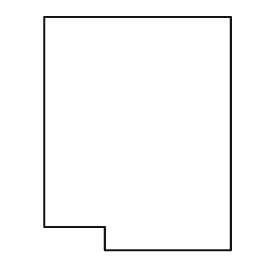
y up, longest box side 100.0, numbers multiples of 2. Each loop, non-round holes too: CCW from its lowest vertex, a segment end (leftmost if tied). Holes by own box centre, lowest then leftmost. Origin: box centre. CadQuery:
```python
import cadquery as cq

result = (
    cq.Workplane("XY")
    .moveTo(-14.0, -50.0)
    .lineTo(40.0, -50.0)
    .lineTo(40.0, 50.0)
    .lineTo(-40.0, 50.0)
    .lineTo(-40.0, -40.0)
    .lineTo(-14.0, -40.0)
    .close()
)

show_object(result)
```